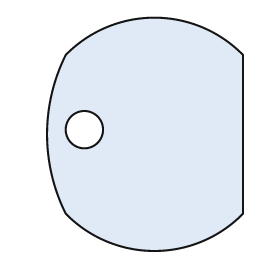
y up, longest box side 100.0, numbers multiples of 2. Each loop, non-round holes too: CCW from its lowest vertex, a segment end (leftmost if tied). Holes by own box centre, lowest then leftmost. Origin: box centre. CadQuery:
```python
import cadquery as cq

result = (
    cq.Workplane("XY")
    .moveTo(-34.0, -34.0)
    .threePointArc((4.0, -50.0), (42.0, -34.0))
    .lineTo(42.0, 34.0)
    .threePointArc((4.0, 50.0), (-34.0, 34.0))
    .threePointArc((-42.0, 0.0), (-34.0, -34.0))
    .close()
    .moveTo(-26.0, 2.0)
    .circle(8.0)
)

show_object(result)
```